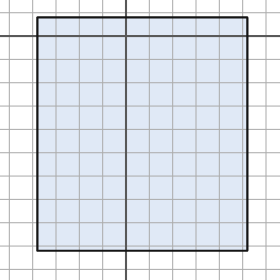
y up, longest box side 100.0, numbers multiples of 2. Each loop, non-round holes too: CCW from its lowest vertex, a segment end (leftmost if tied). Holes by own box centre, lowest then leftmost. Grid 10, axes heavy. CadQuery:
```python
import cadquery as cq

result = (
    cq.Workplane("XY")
    .moveTo(-38.0, -92.0)
    .lineTo(52.0, -92.0)
    .lineTo(52.0, 8.0)
    .lineTo(-38.0, 8.0)
    .close()
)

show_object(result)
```